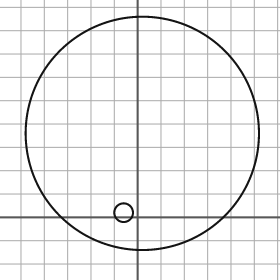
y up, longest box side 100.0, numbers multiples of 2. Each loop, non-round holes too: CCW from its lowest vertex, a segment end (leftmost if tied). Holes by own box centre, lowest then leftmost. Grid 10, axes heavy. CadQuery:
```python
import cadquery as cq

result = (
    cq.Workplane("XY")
    .moveTo(2.0, 36.0)
    .circle(50.0)
    .moveTo(-6.0, 2.0)
    .circle(4.0)
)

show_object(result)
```